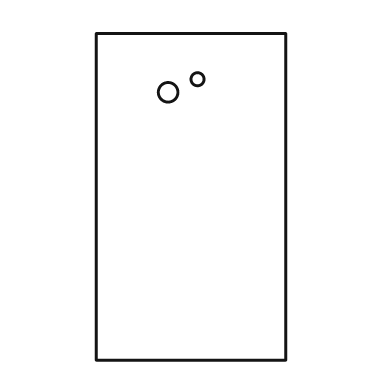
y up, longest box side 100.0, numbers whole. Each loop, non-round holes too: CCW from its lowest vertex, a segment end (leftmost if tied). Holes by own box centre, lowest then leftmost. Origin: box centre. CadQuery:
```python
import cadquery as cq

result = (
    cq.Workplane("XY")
    .moveTo(-29.0, -50.0)
    .lineTo(29.0, -50.0)
    .lineTo(29.0, 50.0)
    .lineTo(-29.0, 50.0)
    .close()
    .moveTo(-7.0, 32.0)
    .circle(3.0)
    .moveTo(2.0, 36.0)
    .circle(2.0)
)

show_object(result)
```